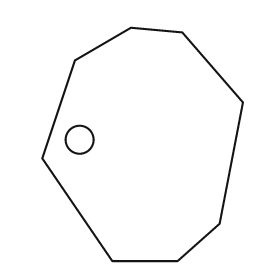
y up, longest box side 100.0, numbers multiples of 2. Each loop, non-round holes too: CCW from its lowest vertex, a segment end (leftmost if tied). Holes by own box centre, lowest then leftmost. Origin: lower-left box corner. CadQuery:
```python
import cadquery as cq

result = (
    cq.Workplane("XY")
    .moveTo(30.0, 0.0)
    .lineTo(58.0, 0.0)
    .lineTo(76.0, 16.0)
    .lineTo(86.0, 68.0)
    .lineTo(60.0, 98.0)
    .lineTo(38.0, 100.0)
    .lineTo(14.0, 86.0)
    .lineTo(0.0, 44.0)
    .close()
    .moveTo(16.0, 52.0)
    .circle(6.0)
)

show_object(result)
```